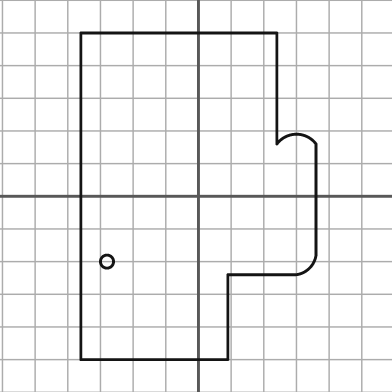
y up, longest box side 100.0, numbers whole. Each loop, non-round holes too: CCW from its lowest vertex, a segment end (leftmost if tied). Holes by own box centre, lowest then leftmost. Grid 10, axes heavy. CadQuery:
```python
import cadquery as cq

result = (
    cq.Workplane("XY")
    .moveTo(-36.0, -50.0)
    .lineTo(9.0, -50.0)
    .lineTo(9.0, -24.0)
    .lineTo(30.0, -24.0)
    .threePointArc((34.0, -22.0), (36.0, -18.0))
    .lineTo(36.0, 16.0)
    .threePointArc((30.0, 19.0), (24.0, 16.0))
    .lineTo(24.0, 50.0)
    .lineTo(-36.0, 50.0)
    .close()
    .moveTo(-28.0, -20.0)
    .circle(2.0)
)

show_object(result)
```